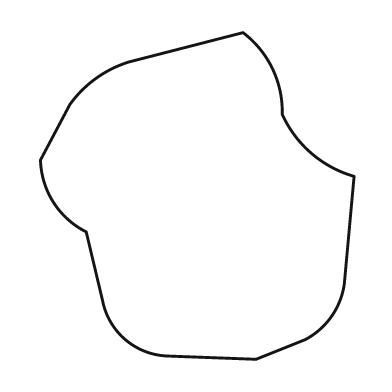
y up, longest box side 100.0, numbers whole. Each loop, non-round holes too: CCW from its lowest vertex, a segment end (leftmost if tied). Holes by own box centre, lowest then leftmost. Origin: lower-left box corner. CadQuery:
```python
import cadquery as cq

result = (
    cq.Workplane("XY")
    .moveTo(66.0, 0.0)
    .lineTo(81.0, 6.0)
    .threePointArc((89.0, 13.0), (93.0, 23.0))
    .lineTo(96.0, 56.0)
    .threePointArc((83.0, 63.0), (74.0, 75.0))
    .threePointArc((71.0, 89.0), (62.0, 100.0))
    .lineTo(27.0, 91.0)
    .threePointArc((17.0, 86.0), (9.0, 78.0))
    .lineTo(0.0, 61.0)
    .threePointArc((4.0, 48.0), (14.0, 39.0))
    .lineTo(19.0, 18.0)
    .threePointArc((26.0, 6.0), (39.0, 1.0))
    .close()
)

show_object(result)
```